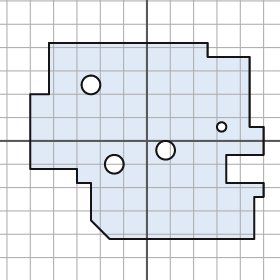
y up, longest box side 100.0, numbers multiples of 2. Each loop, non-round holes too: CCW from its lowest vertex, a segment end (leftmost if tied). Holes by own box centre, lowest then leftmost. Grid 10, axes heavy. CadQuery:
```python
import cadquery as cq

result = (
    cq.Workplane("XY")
    .moveTo(-16.0, -42.0)
    .lineTo(46.0, -42.0)
    .lineTo(46.0, -24.0)
    .lineTo(50.0, -24.0)
    .lineTo(50.0, -18.0)
    .lineTo(34.0, -18.0)
    .lineTo(34.0, -6.0)
    .lineTo(50.0, -6.0)
    .lineTo(50.0, 6.0)
    .lineTo(44.0, 6.0)
    .lineTo(44.0, 36.0)
    .lineTo(26.0, 36.0)
    .lineTo(26.0, 42.0)
    .lineTo(-42.0, 42.0)
    .lineTo(-42.0, 20.0)
    .lineTo(-50.0, 20.0)
    .lineTo(-50.0, -12.0)
    .lineTo(-30.0, -12.0)
    .lineTo(-30.0, -18.0)
    .lineTo(-24.0, -18.0)
    .lineTo(-24.0, -34.0)
    .close()
    .moveTo(-14.0, -10.0)
    .circle(4.0)
    .moveTo(8.0, -4.0)
    .circle(4.0)
    .moveTo(32.0, 6.0)
    .circle(2.0)
    .moveTo(-24.0, 24.0)
    .circle(4.0)
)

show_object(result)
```